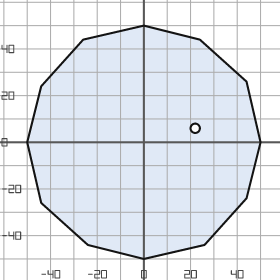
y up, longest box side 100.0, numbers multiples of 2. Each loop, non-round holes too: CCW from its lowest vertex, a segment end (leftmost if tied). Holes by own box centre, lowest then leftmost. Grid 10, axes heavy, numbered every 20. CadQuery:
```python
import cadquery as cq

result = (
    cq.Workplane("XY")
    .moveTo(0.0, -50.0)
    .lineTo(26.0, -44.0)
    .lineTo(44.0, -24.0)
    .lineTo(50.0, 0.0)
    .lineTo(44.0, 26.0)
    .lineTo(24.0, 44.0)
    .lineTo(0.0, 50.0)
    .lineTo(-26.0, 44.0)
    .lineTo(-44.0, 24.0)
    .lineTo(-50.0, 0.0)
    .lineTo(-44.0, -26.0)
    .lineTo(-24.0, -44.0)
    .close()
    .moveTo(22.0, 6.0)
    .circle(2.0)
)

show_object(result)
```